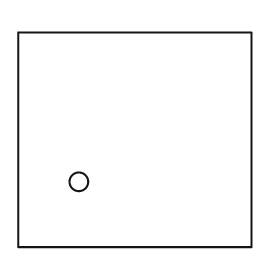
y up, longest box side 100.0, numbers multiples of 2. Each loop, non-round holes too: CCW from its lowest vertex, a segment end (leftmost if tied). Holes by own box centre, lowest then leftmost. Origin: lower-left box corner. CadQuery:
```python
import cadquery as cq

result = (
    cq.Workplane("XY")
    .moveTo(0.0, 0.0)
    .lineTo(100.0, 0.0)
    .lineTo(100.0, 92.0)
    .lineTo(0.0, 92.0)
    .close()
    .moveTo(26.0, 28.0)
    .circle(4.0)
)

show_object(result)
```